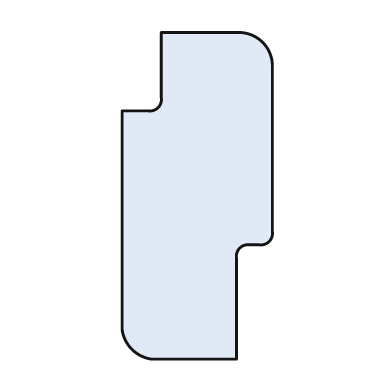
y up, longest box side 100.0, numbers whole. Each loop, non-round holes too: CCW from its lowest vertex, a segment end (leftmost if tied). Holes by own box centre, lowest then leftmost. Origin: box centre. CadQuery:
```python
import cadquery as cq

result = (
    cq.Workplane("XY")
    .moveTo(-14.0, -50.0)
    .lineTo(12.0, -50.0)
    .lineTo(12.0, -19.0)
    .threePointArc((13.0, -16.0), (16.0, -15.0))
    .lineTo(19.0, -15.0)
    .threePointArc((22.0, -14.0), (23.0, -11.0))
    .lineTo(23.0, 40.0)
    .threePointArc((20.0, 47.0), (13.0, 50.0))
    .lineTo(-11.0, 50.0)
    .lineTo(-11.0, 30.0)
    .threePointArc((-12.0, 27.0), (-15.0, 26.0))
    .lineTo(-23.0, 26.0)
    .lineTo(-23.0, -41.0)
    .threePointArc((-20.0, -47.0), (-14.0, -50.0))
    .close()
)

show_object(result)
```